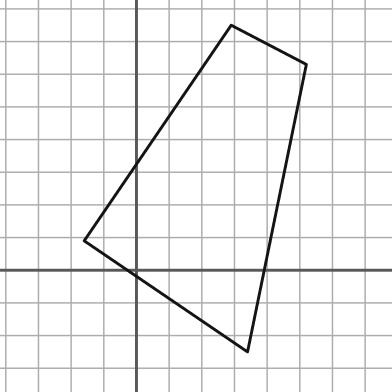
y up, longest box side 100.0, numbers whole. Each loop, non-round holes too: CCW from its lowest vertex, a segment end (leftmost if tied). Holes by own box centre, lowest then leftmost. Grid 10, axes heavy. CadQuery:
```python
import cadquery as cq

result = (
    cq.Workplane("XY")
    .moveTo(34.0, -25.0)
    .lineTo(52.0, 63.0)
    .lineTo(29.0, 75.0)
    .lineTo(-16.0, 9.0)
    .close()
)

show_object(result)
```